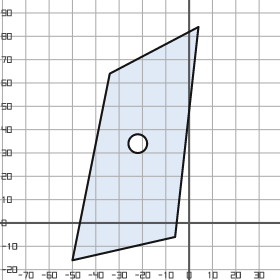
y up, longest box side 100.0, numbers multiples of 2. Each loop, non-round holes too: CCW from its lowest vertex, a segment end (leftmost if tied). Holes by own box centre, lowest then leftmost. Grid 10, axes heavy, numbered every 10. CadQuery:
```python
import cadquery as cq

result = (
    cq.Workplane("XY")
    .moveTo(-50.0, -16.0)
    .lineTo(-6.0, -6.0)
    .lineTo(4.0, 84.0)
    .lineTo(-34.0, 64.0)
    .close()
    .moveTo(-22.0, 34.0)
    .circle(4.0)
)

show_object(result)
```